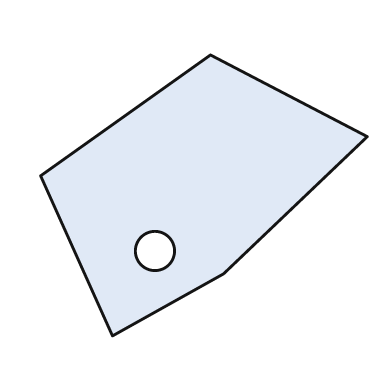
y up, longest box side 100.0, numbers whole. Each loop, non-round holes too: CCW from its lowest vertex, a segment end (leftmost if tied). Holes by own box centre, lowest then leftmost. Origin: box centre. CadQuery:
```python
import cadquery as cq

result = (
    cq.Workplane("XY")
    .moveTo(-28.0, -43.0)
    .lineTo(6.0, -24.0)
    .lineTo(50.0, 18.0)
    .lineTo(2.0, 43.0)
    .lineTo(-50.0, 6.0)
    .close()
    .moveTo(-15.0, -17.0)
    .circle(6.0)
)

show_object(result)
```